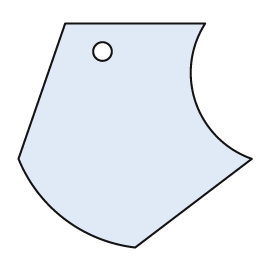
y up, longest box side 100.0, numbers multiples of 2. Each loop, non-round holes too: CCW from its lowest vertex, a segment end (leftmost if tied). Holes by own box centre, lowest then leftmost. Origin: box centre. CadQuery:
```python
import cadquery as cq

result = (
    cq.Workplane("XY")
    .moveTo(0.0, -48.0)
    .lineTo(50.0, -10.0)
    .threePointArc((26.0, 14.0), (30.0, 48.0))
    .lineTo(-30.0, 48.0)
    .lineTo(-50.0, -10.0)
    .threePointArc((-30.0, -36.0), (0.0, -48.0))
    .close()
    .moveTo(-14.0, 36.0)
    .circle(4.0)
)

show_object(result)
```